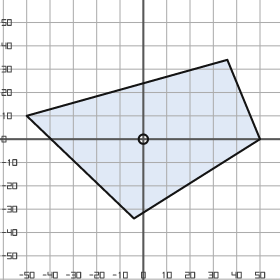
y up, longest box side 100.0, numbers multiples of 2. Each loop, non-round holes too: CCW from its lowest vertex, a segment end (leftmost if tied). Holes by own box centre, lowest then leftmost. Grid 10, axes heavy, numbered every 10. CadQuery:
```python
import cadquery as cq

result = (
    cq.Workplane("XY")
    .moveTo(-4.0, -34.0)
    .lineTo(50.0, 0.0)
    .lineTo(36.0, 34.0)
    .lineTo(-50.0, 10.0)
    .close()
    .moveTo(0.0, 0.0)
    .circle(2.0)
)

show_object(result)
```